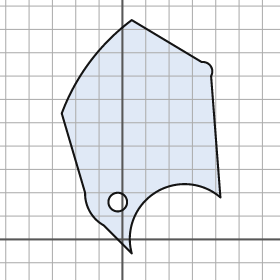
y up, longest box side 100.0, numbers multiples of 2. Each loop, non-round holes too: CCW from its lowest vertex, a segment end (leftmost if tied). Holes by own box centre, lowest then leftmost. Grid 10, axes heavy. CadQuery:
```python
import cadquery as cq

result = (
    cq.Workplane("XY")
    .moveTo(4.0, -6.0)
    .threePointArc((14.0, 20.0), (42.0, 18.0))
    .lineTo(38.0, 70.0)
    .threePointArc((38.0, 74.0), (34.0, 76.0))
    .lineTo(4.0, 94.0)
    .threePointArc((-14.0, 76.0), (-26.0, 54.0))
    .lineTo(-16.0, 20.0)
    .threePointArc((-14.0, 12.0), (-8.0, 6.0))
    .close()
    .moveTo(-2.0, 16.0)
    .circle(4.0)
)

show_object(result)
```